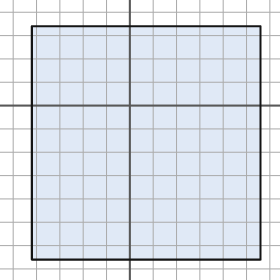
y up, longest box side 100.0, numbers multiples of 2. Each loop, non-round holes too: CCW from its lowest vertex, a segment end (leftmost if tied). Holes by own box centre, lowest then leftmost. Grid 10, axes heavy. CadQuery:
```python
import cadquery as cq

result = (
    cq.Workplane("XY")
    .moveTo(-42.0, -66.0)
    .lineTo(56.0, -66.0)
    .lineTo(56.0, 34.0)
    .lineTo(-42.0, 34.0)
    .close()
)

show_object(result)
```